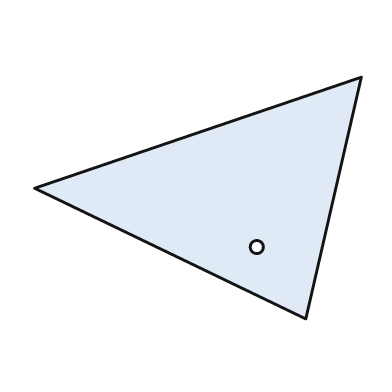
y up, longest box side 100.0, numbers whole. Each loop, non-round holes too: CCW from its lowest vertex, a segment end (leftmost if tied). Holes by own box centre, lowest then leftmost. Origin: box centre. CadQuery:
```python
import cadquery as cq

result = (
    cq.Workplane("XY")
    .moveTo(33.0, -37.0)
    .lineTo(50.0, 37.0)
    .lineTo(-50.0, 3.0)
    .close()
    .moveTo(18.0, -15.0)
    .circle(2.0)
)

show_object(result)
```